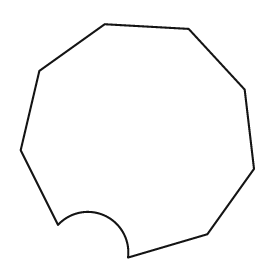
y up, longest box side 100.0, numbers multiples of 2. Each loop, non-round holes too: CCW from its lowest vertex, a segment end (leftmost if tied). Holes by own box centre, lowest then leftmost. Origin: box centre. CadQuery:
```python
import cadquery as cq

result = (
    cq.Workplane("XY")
    .moveTo(-4.0, -50.0)
    .lineTo(30.0, -40.0)
    .lineTo(50.0, -12.0)
    .lineTo(46.0, 22.0)
    .lineTo(22.0, 48.0)
    .lineTo(-14.0, 50.0)
    .lineTo(-42.0, 30.0)
    .lineTo(-50.0, -4.0)
    .lineTo(-34.0, -36.0)
    .threePointArc((-14.0, -32.0), (-4.0, -50.0))
    .close()
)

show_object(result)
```